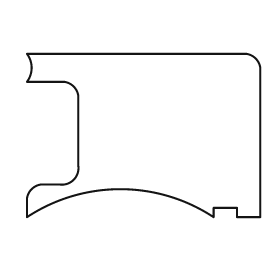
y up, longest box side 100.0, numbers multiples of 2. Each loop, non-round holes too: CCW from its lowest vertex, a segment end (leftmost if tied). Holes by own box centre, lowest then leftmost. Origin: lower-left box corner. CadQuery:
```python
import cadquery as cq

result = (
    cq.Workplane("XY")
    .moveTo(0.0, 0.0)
    .threePointArc((40.0, 12.0), (80.0, 0.0))
    .lineTo(80.0, 4.0)
    .lineTo(90.0, 4.0)
    .lineTo(90.0, 0.0)
    .lineTo(100.0, 0.0)
    .lineTo(100.0, 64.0)
    .threePointArc((98.0, 68.0), (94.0, 70.0))
    .lineTo(0.0, 70.0)
    .threePointArc((2.0, 64.0), (0.0, 58.0))
    .lineTo(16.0, 58.0)
    .threePointArc((20.0, 56.0), (22.0, 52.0))
    .lineTo(22.0, 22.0)
    .threePointArc((20.0, 16.0), (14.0, 14.0))
    .lineTo(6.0, 14.0)
    .threePointArc((2.0, 12.0), (0.0, 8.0))
    .close()
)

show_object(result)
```